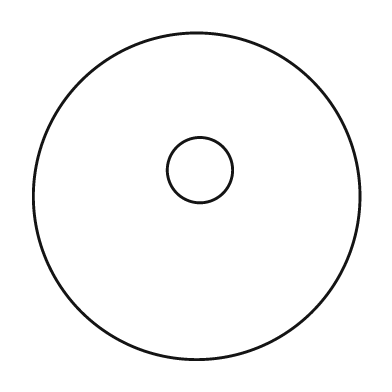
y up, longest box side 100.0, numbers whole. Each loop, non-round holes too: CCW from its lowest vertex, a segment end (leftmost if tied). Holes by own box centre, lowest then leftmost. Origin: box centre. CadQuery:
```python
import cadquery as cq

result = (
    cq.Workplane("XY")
    .moveTo(0.0, 0.0)
    .circle(50.0)
    .moveTo(1.0, 8.0)
    .circle(10.0)
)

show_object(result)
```